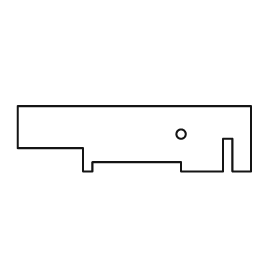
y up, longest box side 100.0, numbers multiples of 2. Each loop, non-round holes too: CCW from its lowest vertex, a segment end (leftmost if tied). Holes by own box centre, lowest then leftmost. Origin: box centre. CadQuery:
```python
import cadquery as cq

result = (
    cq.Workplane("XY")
    .moveTo(-22.0, -14.0)
    .lineTo(-18.0, -14.0)
    .lineTo(-18.0, -10.0)
    .lineTo(20.0, -10.0)
    .lineTo(20.0, -14.0)
    .lineTo(38.0, -14.0)
    .lineTo(38.0, 0.0)
    .lineTo(42.0, 0.0)
    .lineTo(42.0, -14.0)
    .lineTo(50.0, -14.0)
    .lineTo(50.0, 14.0)
    .lineTo(-50.0, 14.0)
    .lineTo(-50.0, -4.0)
    .lineTo(-22.0, -4.0)
    .close()
    .moveTo(20.0, 2.0)
    .circle(2.0)
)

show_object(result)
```